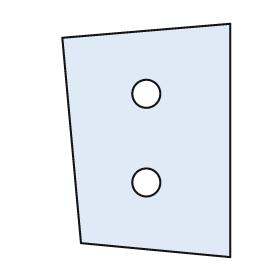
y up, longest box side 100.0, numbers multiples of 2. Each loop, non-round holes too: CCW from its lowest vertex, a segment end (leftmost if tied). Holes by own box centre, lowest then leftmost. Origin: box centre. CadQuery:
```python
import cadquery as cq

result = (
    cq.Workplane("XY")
    .moveTo(36.0, -50.0)
    .lineTo(36.0, 50.0)
    .lineTo(-36.0, 44.0)
    .lineTo(-28.0, -44.0)
    .close()
    .moveTo(0.0, -18.0)
    .circle(6.0)
    .moveTo(0.0, 20.0)
    .circle(6.0)
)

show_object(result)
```